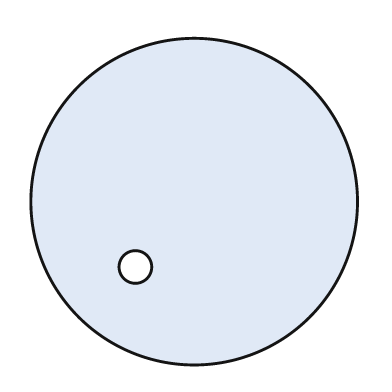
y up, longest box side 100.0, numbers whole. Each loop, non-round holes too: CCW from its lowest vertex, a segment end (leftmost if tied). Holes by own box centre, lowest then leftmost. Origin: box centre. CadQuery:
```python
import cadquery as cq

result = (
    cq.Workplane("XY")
    .moveTo(0.0, 0.0)
    .circle(50.0)
    .moveTo(-18.0, -20.0)
    .circle(5.0)
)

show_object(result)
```